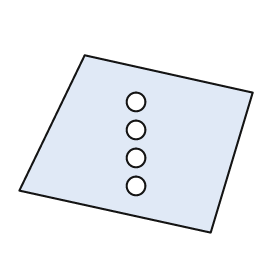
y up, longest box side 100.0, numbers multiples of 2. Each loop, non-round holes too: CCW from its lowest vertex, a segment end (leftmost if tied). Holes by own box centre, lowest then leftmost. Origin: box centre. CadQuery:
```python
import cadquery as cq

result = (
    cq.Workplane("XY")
    .moveTo(32.0, -38.0)
    .lineTo(50.0, 22.0)
    .lineTo(-22.0, 38.0)
    .lineTo(-50.0, -20.0)
    .close()
    .moveTo(0.0, -18.0)
    .circle(4.0)
    .moveTo(0.0, -6.0)
    .circle(4.0)
    .moveTo(0.0, 6.0)
    .circle(4.0)
    .moveTo(0.0, 18.0)
    .circle(4.0)
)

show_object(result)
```